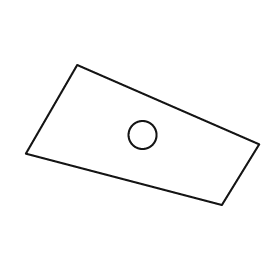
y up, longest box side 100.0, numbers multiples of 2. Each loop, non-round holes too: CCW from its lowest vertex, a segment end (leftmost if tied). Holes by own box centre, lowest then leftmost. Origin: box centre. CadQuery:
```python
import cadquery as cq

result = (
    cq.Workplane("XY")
    .moveTo(34.0, -30.0)
    .lineTo(50.0, -4.0)
    .lineTo(-28.0, 30.0)
    .lineTo(-50.0, -8.0)
    .close()
    .moveTo(0.0, 0.0)
    .circle(6.0)
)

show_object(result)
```